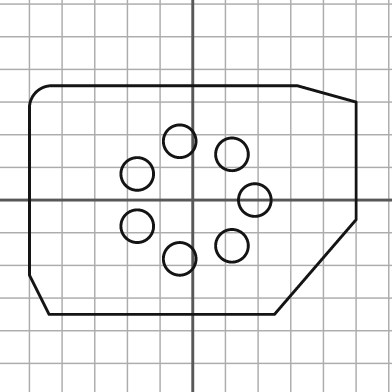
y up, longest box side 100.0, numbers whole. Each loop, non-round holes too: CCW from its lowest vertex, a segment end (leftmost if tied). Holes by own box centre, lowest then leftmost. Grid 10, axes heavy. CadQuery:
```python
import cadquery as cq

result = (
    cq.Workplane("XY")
    .moveTo(-44.0, -35.0)
    .lineTo(25.0, -35.0)
    .lineTo(50.0, -6.0)
    .lineTo(50.0, 30.0)
    .lineTo(32.0, 35.0)
    .lineTo(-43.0, 35.0)
    .threePointArc((-48.0, 33.0), (-50.0, 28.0))
    .lineTo(-50.0, -23.0)
    .close()
    .moveTo(-4.0, -18.0)
    .circle(5.0)
    .moveTo(12.0, -14.0)
    .circle(5.0)
    .moveTo(-17.0, -8.0)
    .circle(5.0)
    .moveTo(19.0, 0.0)
    .circle(5.0)
    .moveTo(-17.0, 8.0)
    .circle(5.0)
    .moveTo(12.0, 14.0)
    .circle(5.0)
    .moveTo(-4.0, 18.0)
    .circle(5.0)
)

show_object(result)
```